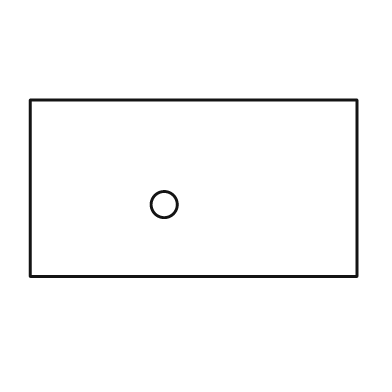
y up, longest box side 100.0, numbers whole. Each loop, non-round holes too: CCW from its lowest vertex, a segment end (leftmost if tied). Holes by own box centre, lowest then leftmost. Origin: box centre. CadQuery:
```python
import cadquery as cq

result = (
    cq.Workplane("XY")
    .moveTo(-50.0, -27.0)
    .lineTo(50.0, -27.0)
    .lineTo(50.0, 27.0)
    .lineTo(-50.0, 27.0)
    .close()
    .moveTo(-9.0, -5.0)
    .circle(4.0)
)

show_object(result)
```